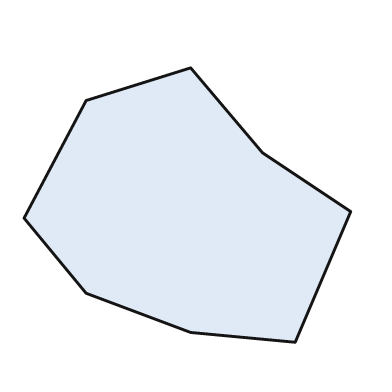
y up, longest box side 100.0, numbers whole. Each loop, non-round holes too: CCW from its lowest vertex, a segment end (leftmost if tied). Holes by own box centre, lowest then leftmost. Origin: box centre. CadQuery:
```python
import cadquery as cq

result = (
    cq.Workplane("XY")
    .moveTo(33.0, -42.0)
    .lineTo(50.0, -2.0)
    .lineTo(23.0, 16.0)
    .lineTo(1.0, 42.0)
    .lineTo(-31.0, 32.0)
    .lineTo(-50.0, -4.0)
    .lineTo(-31.0, -27.0)
    .lineTo(1.0, -39.0)
    .close()
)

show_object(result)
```